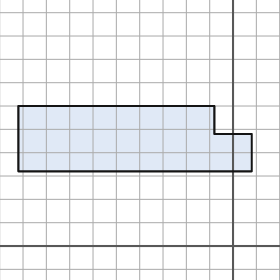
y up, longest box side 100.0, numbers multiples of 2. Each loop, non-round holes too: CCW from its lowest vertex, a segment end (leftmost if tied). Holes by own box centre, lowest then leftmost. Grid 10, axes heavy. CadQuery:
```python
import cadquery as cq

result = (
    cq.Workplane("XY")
    .moveTo(-92.0, 32.0)
    .lineTo(8.0, 32.0)
    .lineTo(8.0, 48.0)
    .lineTo(-8.0, 48.0)
    .lineTo(-8.0, 60.0)
    .lineTo(-92.0, 60.0)
    .close()
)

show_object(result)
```